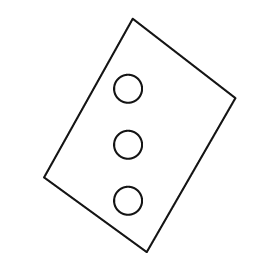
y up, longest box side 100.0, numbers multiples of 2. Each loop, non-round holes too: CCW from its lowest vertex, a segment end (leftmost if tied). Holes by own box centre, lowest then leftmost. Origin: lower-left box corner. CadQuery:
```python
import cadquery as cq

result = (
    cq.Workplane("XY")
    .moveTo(44.0, 0.0)
    .lineTo(82.0, 66.0)
    .lineTo(38.0, 100.0)
    .lineTo(0.0, 32.0)
    .close()
    .moveTo(36.0, 22.0)
    .circle(6.0)
    .moveTo(36.0, 46.0)
    .circle(6.0)
    .moveTo(36.0, 70.0)
    .circle(6.0)
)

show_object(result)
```